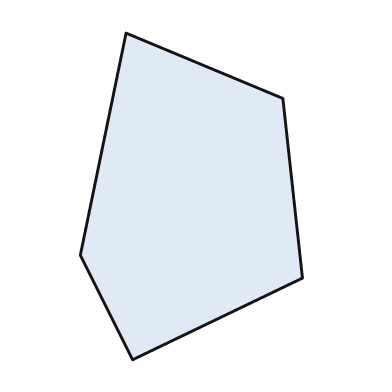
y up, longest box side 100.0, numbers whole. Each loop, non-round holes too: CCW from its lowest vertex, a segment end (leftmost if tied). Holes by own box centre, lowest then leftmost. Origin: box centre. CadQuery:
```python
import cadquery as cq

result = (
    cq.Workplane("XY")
    .moveTo(-18.0, -50.0)
    .lineTo(34.0, -25.0)
    .lineTo(28.0, 30.0)
    .lineTo(-20.0, 50.0)
    .lineTo(-34.0, -18.0)
    .close()
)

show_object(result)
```